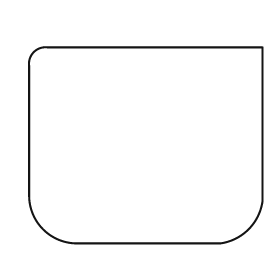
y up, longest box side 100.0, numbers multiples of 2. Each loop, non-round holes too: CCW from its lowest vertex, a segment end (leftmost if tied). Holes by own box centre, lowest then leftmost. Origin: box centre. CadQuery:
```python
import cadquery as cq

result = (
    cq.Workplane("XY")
    .moveTo(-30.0, -42.0)
    .lineTo(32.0, -42.0)
    .threePointArc((44.0, -36.0), (50.0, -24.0))
    .lineTo(50.0, 42.0)
    .lineTo(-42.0, 42.0)
    .threePointArc((-48.0, 40.0), (-50.0, 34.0))
    .lineTo(-50.0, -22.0)
    .threePointArc((-44.0, -36.0), (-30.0, -42.0))
    .close()
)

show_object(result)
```